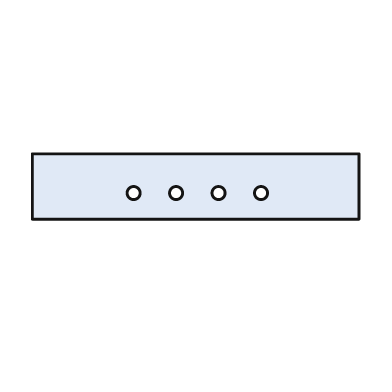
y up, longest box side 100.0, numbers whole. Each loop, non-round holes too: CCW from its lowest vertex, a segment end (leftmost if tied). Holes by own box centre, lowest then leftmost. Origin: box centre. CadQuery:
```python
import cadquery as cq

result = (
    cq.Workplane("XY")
    .moveTo(-50.0, -10.0)
    .lineTo(50.0, -10.0)
    .lineTo(50.0, 10.0)
    .lineTo(-50.0, 10.0)
    .close()
    .moveTo(-19.0, -2.0)
    .circle(2.0)
    .moveTo(-6.0, -2.0)
    .circle(2.0)
    .moveTo(7.0, -2.0)
    .circle(2.0)
    .moveTo(20.0, -2.0)
    .circle(2.0)
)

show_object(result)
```